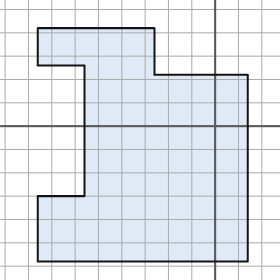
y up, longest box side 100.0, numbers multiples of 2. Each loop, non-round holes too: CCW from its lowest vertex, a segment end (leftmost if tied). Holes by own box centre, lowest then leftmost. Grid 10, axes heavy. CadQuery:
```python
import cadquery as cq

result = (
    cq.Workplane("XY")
    .moveTo(-76.0, -58.0)
    .lineTo(14.0, -58.0)
    .lineTo(14.0, 22.0)
    .lineTo(-26.0, 22.0)
    .lineTo(-26.0, 42.0)
    .lineTo(-76.0, 42.0)
    .lineTo(-76.0, 26.0)
    .lineTo(-56.0, 26.0)
    .lineTo(-56.0, -30.0)
    .lineTo(-76.0, -30.0)
    .close()
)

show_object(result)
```